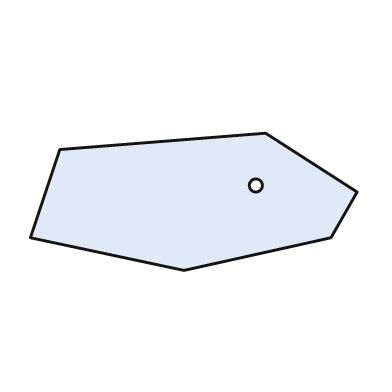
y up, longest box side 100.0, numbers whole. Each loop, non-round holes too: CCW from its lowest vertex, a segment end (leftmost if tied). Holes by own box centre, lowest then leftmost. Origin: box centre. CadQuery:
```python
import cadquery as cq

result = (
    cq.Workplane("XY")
    .moveTo(-3.0, -21.0)
    .lineTo(42.0, -11.0)
    .lineTo(50.0, 3.0)
    .lineTo(22.0, 21.0)
    .lineTo(-41.0, 16.0)
    .lineTo(-50.0, -11.0)
    .close()
    .moveTo(19.0, 5.0)
    .circle(2.0)
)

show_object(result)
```